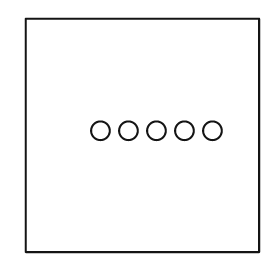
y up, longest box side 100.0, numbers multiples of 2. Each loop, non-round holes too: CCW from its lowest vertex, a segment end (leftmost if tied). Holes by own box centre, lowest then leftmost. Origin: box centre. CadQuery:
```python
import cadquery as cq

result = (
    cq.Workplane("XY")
    .moveTo(-50.0, -50.0)
    .lineTo(50.0, -50.0)
    .lineTo(50.0, 50.0)
    .lineTo(-50.0, 50.0)
    .close()
    .moveTo(-18.0, 2.0)
    .circle(4.0)
    .moveTo(-6.0, 2.0)
    .circle(4.0)
    .moveTo(6.0, 2.0)
    .circle(4.0)
    .moveTo(18.0, 2.0)
    .circle(4.0)
    .moveTo(30.0, 2.0)
    .circle(4.0)
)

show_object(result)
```